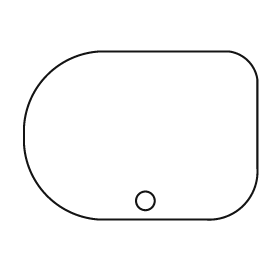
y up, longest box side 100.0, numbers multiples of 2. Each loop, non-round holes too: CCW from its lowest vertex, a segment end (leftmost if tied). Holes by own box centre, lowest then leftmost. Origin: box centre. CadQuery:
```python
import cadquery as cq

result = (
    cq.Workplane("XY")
    .moveTo(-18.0, -36.0)
    .lineTo(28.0, -36.0)
    .threePointArc((44.0, -30.0), (50.0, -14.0))
    .lineTo(50.0, 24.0)
    .threePointArc((46.0, 32.0), (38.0, 36.0))
    .lineTo(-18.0, 36.0)
    .threePointArc((-40.0, 26.0), (-50.0, 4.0))
    .lineTo(-50.0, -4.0)
    .threePointArc((-40.0, -26.0), (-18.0, -36.0))
    .close()
    .moveTo(2.0, -28.0)
    .circle(4.0)
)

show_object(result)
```